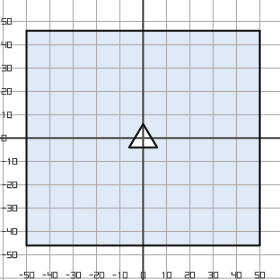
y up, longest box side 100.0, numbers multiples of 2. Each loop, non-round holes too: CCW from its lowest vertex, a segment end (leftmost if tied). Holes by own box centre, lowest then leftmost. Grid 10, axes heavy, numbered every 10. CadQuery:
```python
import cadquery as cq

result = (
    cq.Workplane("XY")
    .moveTo(-50.0, -46.0)
    .lineTo(50.0, -46.0)
    .lineTo(50.0, 46.0)
    .lineTo(-50.0, 46.0)
    .close()
    .moveTo(-6.0, -4.0)
    .lineTo(6.0, -4.0)
    .lineTo(0.0, 6.0)
    .close()
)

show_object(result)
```